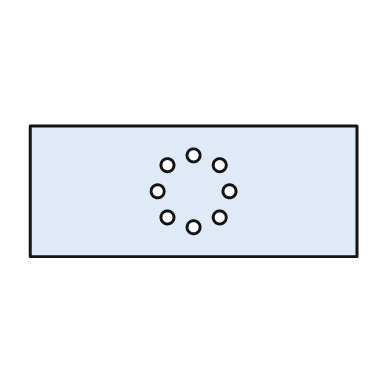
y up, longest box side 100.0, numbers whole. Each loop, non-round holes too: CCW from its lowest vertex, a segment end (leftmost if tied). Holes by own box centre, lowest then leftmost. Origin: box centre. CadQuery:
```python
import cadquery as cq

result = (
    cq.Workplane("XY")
    .moveTo(-50.0, -20.0)
    .lineTo(50.0, -20.0)
    .lineTo(50.0, 20.0)
    .lineTo(-50.0, 20.0)
    .close()
    .moveTo(0.0, -11.0)
    .circle(2.0)
    .moveTo(-8.0, -8.0)
    .circle(2.0)
    .moveTo(8.0, -8.0)
    .circle(2.0)
    .moveTo(-11.0, 0.0)
    .circle(2.0)
    .moveTo(11.0, 0.0)
    .circle(2.0)
    .moveTo(-8.0, 8.0)
    .circle(2.0)
    .moveTo(8.0, 8.0)
    .circle(2.0)
    .moveTo(0.0, 11.0)
    .circle(2.0)
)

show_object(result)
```